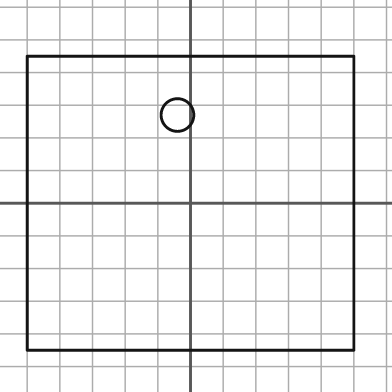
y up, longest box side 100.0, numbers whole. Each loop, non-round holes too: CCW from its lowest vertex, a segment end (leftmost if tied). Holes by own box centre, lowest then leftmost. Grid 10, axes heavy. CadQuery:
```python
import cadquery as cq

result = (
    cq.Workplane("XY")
    .moveTo(-50.0, -45.0)
    .lineTo(50.0, -45.0)
    .lineTo(50.0, 45.0)
    .lineTo(-50.0, 45.0)
    .close()
    .moveTo(-4.0, 27.0)
    .circle(5.0)
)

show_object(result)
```